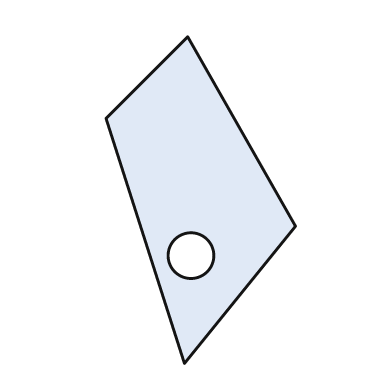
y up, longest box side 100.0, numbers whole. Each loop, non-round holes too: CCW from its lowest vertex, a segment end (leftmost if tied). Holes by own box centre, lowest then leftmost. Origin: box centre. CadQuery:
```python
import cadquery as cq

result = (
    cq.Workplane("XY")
    .moveTo(-5.0, -50.0)
    .lineTo(29.0, -8.0)
    .lineTo(-4.0, 50.0)
    .lineTo(-29.0, 25.0)
    .close()
    .moveTo(-3.0, -17.0)
    .circle(7.0)
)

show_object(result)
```